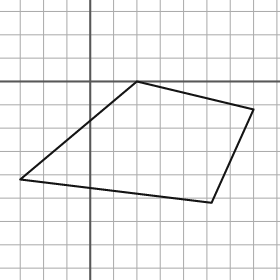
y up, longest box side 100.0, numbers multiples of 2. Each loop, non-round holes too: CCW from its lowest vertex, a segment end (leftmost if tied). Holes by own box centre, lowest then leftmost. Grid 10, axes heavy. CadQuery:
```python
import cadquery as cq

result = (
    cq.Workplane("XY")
    .moveTo(52.0, -52.0)
    .lineTo(70.0, -12.0)
    .lineTo(20.0, 0.0)
    .lineTo(-30.0, -42.0)
    .close()
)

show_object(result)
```